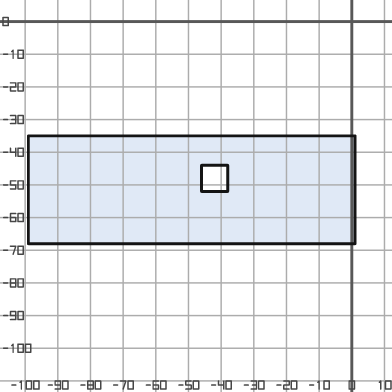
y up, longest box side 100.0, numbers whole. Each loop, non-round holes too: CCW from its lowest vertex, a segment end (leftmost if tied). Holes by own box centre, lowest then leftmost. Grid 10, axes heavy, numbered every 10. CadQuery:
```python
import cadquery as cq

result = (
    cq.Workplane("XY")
    .moveTo(-99.0, -68.0)
    .lineTo(1.0, -68.0)
    .lineTo(1.0, -35.0)
    .lineTo(-99.0, -35.0)
    .close()
    .moveTo(-46.0, -52.0)
    .lineTo(-38.0, -52.0)
    .lineTo(-38.0, -44.0)
    .lineTo(-46.0, -44.0)
    .close()
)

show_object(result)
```